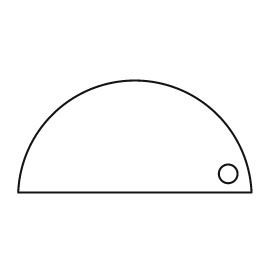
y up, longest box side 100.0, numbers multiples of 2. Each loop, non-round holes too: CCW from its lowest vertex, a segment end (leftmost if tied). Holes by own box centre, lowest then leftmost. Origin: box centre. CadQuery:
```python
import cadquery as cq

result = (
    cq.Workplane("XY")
    .moveTo(-50.0, -24.0)
    .lineTo(50.0, -24.0)
    .threePointArc((0.0, 24.0), (-50.0, -24.0))
    .close()
    .moveTo(40.0, -16.0)
    .circle(4.0)
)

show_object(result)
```